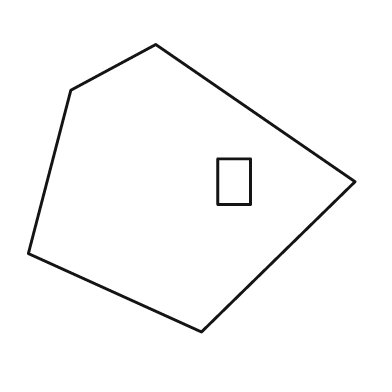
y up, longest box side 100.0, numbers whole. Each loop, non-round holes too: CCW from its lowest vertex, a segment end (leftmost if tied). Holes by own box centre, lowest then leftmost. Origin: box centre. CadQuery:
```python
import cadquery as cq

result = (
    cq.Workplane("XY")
    .moveTo(3.0, -44.0)
    .lineTo(50.0, 2.0)
    .lineTo(-11.0, 44.0)
    .lineTo(-37.0, 30.0)
    .lineTo(-50.0, -20.0)
    .close()
    .moveTo(8.0, -5.0)
    .lineTo(18.0, -5.0)
    .lineTo(18.0, 9.0)
    .lineTo(8.0, 9.0)
    .close()
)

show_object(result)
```